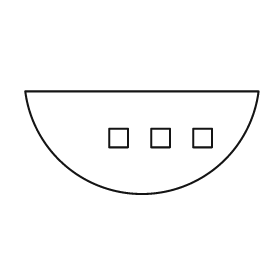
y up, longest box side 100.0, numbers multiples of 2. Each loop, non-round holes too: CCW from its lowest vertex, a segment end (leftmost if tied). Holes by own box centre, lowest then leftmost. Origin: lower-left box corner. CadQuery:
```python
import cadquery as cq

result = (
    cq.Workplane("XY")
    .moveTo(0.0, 44.0)
    .threePointArc((50.0, 0.0), (100.0, 44.0))
    .close()
    .moveTo(36.0, 20.0)
    .lineTo(44.0, 20.0)
    .lineTo(44.0, 28.0)
    .lineTo(36.0, 28.0)
    .close()
    .moveTo(54.0, 20.0)
    .lineTo(62.0, 20.0)
    .lineTo(62.0, 28.0)
    .lineTo(54.0, 28.0)
    .close()
    .moveTo(72.0, 20.0)
    .lineTo(80.0, 20.0)
    .lineTo(80.0, 28.0)
    .lineTo(72.0, 28.0)
    .close()
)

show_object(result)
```